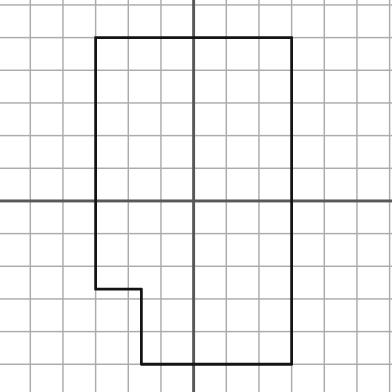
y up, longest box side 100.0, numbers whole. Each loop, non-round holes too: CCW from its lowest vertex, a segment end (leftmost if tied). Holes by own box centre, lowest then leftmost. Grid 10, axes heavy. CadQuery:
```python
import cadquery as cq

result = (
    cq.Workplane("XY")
    .moveTo(-16.0, -50.0)
    .lineTo(30.0, -50.0)
    .lineTo(30.0, 50.0)
    .lineTo(-30.0, 50.0)
    .lineTo(-30.0, -27.0)
    .lineTo(-16.0, -27.0)
    .close()
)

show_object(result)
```